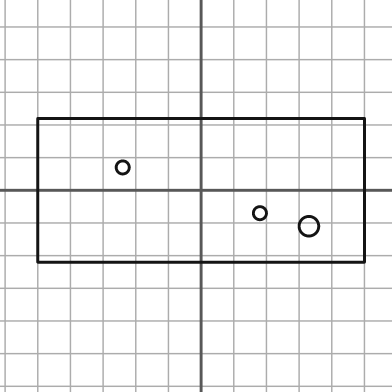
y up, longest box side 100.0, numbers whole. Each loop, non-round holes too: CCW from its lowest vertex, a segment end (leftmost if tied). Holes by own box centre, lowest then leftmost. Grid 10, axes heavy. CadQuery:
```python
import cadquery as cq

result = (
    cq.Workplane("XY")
    .moveTo(-50.0, -22.0)
    .lineTo(50.0, -22.0)
    .lineTo(50.0, 22.0)
    .lineTo(-50.0, 22.0)
    .close()
    .moveTo(33.0, -11.0)
    .circle(3.0)
    .moveTo(18.0, -7.0)
    .circle(2.0)
    .moveTo(-24.0, 7.0)
    .circle(2.0)
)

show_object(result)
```